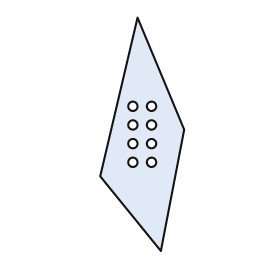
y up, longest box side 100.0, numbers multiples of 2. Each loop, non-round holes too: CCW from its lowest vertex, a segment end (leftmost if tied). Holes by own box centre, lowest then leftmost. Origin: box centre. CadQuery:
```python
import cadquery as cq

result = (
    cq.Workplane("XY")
    .moveTo(8.0, -50.0)
    .lineTo(18.0, 2.0)
    .lineTo(-2.0, 50.0)
    .lineTo(-18.0, -18.0)
    .close()
    .moveTo(-4.0, -12.0)
    .circle(2.0)
    .moveTo(4.0, -12.0)
    .circle(2.0)
    .moveTo(-4.0, -4.0)
    .circle(2.0)
    .moveTo(4.0, -4.0)
    .circle(2.0)
    .moveTo(-4.0, 4.0)
    .circle(2.0)
    .moveTo(4.0, 4.0)
    .circle(2.0)
    .moveTo(-4.0, 12.0)
    .circle(2.0)
    .moveTo(4.0, 12.0)
    .circle(2.0)
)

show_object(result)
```